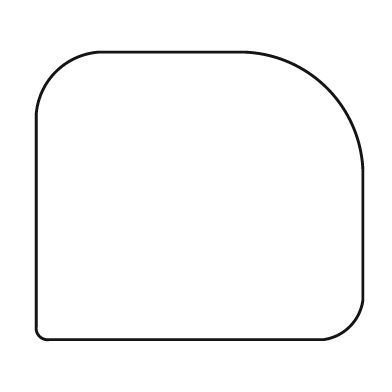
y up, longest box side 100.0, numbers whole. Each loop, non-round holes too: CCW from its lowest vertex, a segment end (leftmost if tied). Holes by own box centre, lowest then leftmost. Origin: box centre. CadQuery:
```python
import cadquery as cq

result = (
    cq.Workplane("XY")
    .moveTo(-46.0, -44.0)
    .lineTo(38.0, -44.0)
    .threePointArc((46.0, -40.0), (50.0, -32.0))
    .lineTo(50.0, 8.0)
    .threePointArc((39.0, 33.0), (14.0, 44.0))
    .lineTo(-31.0, 44.0)
    .threePointArc((-44.0, 38.0), (-50.0, 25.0))
    .lineTo(-50.0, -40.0)
    .threePointArc((-49.0, -43.0), (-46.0, -44.0))
    .close()
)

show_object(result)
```